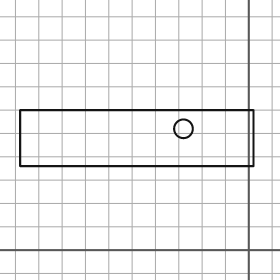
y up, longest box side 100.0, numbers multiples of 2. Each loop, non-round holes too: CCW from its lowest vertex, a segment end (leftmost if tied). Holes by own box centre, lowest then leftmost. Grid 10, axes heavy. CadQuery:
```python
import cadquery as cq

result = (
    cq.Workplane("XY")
    .moveTo(-98.0, 36.0)
    .lineTo(2.0, 36.0)
    .lineTo(2.0, 60.0)
    .lineTo(-98.0, 60.0)
    .close()
    .moveTo(-28.0, 52.0)
    .circle(4.0)
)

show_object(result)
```